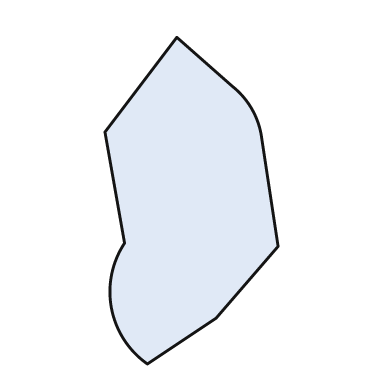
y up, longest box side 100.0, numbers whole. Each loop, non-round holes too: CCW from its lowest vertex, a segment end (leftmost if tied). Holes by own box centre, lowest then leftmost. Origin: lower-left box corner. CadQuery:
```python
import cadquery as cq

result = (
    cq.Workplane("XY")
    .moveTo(13.0, 0.0)
    .lineTo(34.0, 14.0)
    .lineTo(53.0, 36.0)
    .lineTo(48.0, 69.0)
    .threePointArc((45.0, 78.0), (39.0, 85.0))
    .lineTo(22.0, 100.0)
    .lineTo(0.0, 71.0)
    .lineTo(6.0, 37.0)
    .threePointArc((2.0, 17.0), (13.0, 0.0))
    .close()
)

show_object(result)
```